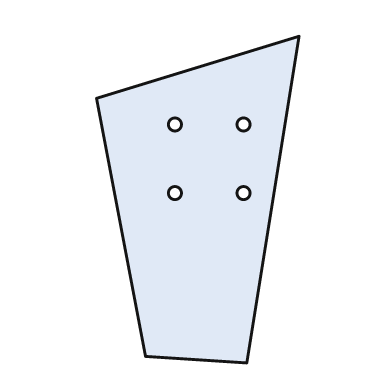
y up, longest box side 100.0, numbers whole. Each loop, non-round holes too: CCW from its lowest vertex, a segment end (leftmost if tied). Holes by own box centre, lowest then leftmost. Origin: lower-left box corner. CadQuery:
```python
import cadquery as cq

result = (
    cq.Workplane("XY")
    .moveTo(46.0, 0.0)
    .lineTo(62.0, 100.0)
    .lineTo(0.0, 81.0)
    .lineTo(15.0, 2.0)
    .close()
    .moveTo(24.0, 52.0)
    .circle(2.0)
    .moveTo(45.0, 52.0)
    .circle(2.0)
    .moveTo(24.0, 73.0)
    .circle(2.0)
    .moveTo(45.0, 73.0)
    .circle(2.0)
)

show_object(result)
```